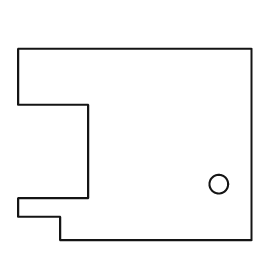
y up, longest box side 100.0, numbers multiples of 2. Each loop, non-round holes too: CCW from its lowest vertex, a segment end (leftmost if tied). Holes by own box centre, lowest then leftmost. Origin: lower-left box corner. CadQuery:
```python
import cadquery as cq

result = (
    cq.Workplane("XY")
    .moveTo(18.0, 0.0)
    .lineTo(100.0, 0.0)
    .lineTo(100.0, 82.0)
    .lineTo(0.0, 82.0)
    .lineTo(0.0, 58.0)
    .lineTo(30.0, 58.0)
    .lineTo(30.0, 18.0)
    .lineTo(0.0, 18.0)
    .lineTo(0.0, 10.0)
    .lineTo(18.0, 10.0)
    .close()
    .moveTo(86.0, 24.0)
    .circle(4.0)
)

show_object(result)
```